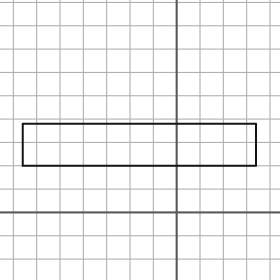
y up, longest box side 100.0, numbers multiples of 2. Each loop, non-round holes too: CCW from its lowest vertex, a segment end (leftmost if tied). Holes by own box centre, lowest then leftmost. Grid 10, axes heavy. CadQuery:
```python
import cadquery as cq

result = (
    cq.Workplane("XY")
    .moveTo(-66.0, 20.0)
    .lineTo(34.0, 20.0)
    .lineTo(34.0, 38.0)
    .lineTo(-66.0, 38.0)
    .close()
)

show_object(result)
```